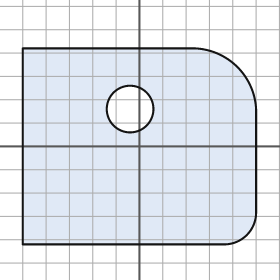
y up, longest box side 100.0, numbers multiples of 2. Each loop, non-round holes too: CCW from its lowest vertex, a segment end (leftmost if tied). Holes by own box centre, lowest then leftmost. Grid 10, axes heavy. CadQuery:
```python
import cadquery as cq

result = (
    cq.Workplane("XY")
    .moveTo(-50.0, -42.0)
    .lineTo(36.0, -42.0)
    .threePointArc((46.0, -38.0), (50.0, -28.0))
    .lineTo(50.0, 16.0)
    .threePointArc((42.0, 34.0), (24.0, 42.0))
    .lineTo(-50.0, 42.0)
    .close()
    .moveTo(-4.0, 16.0)
    .circle(10.0)
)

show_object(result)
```